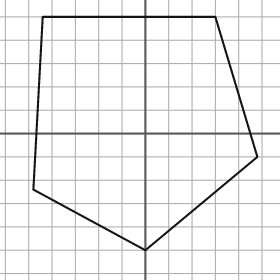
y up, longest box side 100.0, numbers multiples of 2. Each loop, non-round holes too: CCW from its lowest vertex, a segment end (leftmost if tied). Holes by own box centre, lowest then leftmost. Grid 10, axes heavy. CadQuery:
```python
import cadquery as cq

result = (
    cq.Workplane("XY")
    .moveTo(0.0, -50.0)
    .lineTo(48.0, -10.0)
    .lineTo(30.0, 50.0)
    .lineTo(-44.0, 50.0)
    .lineTo(-48.0, -24.0)
    .close()
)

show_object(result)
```